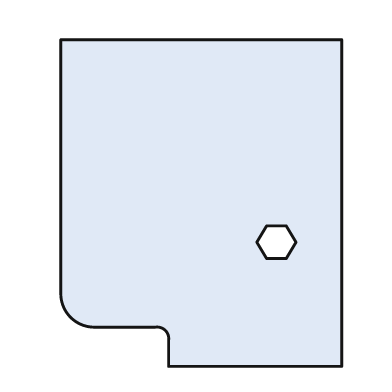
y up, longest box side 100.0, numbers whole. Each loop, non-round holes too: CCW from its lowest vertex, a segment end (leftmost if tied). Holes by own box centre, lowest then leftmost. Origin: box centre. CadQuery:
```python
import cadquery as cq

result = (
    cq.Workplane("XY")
    .moveTo(-10.0, -50.0)
    .lineTo(43.0, -50.0)
    .lineTo(43.0, 50.0)
    .lineTo(-43.0, 50.0)
    .lineTo(-43.0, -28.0)
    .threePointArc((-40.0, -35.0), (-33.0, -38.0))
    .lineTo(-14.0, -38.0)
    .threePointArc((-11.0, -39.0), (-10.0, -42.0))
    .close()
    .moveTo(20.0, -17.0)
    .lineTo(26.0, -17.0)
    .lineTo(29.0, -12.0)
    .lineTo(26.0, -7.0)
    .lineTo(20.0, -7.0)
    .lineTo(17.0, -12.0)
    .close()
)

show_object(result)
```